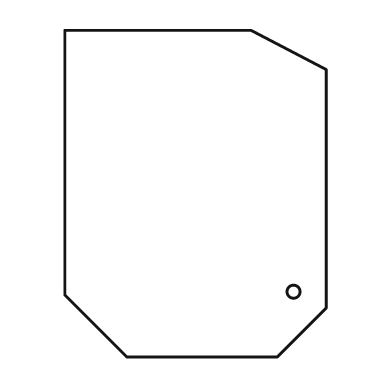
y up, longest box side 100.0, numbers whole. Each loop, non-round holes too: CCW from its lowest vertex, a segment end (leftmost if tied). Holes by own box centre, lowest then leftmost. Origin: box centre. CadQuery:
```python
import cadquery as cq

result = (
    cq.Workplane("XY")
    .moveTo(-21.0, -50.0)
    .lineTo(25.0, -50.0)
    .lineTo(40.0, -35.0)
    .lineTo(40.0, 38.0)
    .lineTo(17.0, 50.0)
    .lineTo(-40.0, 50.0)
    .lineTo(-40.0, -31.0)
    .close()
    .moveTo(30.0, -30.0)
    .circle(2.0)
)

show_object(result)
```